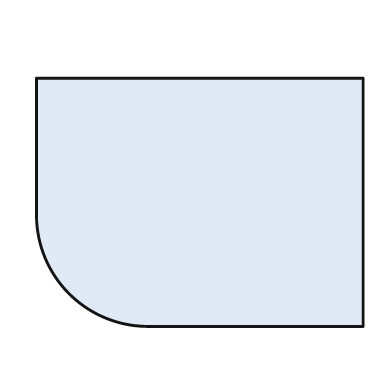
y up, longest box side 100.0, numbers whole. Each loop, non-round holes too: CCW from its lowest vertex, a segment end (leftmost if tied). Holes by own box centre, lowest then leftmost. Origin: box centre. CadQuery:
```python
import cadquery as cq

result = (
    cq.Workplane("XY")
    .moveTo(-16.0, -38.0)
    .lineTo(50.0, -38.0)
    .lineTo(50.0, 38.0)
    .lineTo(-50.0, 38.0)
    .lineTo(-50.0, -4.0)
    .threePointArc((-40.0, -28.0), (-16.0, -38.0))
    .close()
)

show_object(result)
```